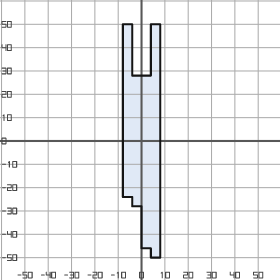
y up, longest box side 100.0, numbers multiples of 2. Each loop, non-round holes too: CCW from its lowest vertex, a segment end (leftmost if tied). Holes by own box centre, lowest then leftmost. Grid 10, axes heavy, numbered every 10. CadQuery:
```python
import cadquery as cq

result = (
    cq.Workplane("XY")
    .moveTo(4.0, -50.0)
    .lineTo(8.0, -50.0)
    .lineTo(8.0, 50.0)
    .lineTo(4.0, 50.0)
    .lineTo(4.0, 28.0)
    .lineTo(-4.0, 28.0)
    .lineTo(-4.0, 50.0)
    .lineTo(-8.0, 50.0)
    .lineTo(-8.0, -24.0)
    .lineTo(-4.0, -24.0)
    .lineTo(-4.0, -28.0)
    .lineTo(0.0, -28.0)
    .lineTo(0.0, -46.0)
    .lineTo(4.0, -46.0)
    .close()
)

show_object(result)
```